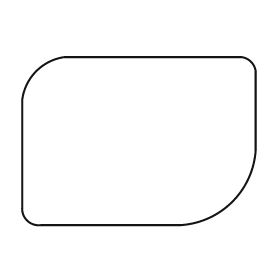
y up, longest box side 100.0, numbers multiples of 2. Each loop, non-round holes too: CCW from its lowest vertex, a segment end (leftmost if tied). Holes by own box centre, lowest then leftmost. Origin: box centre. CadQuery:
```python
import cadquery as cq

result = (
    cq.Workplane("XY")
    .moveTo(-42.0, -36.0)
    .lineTo(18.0, -36.0)
    .threePointArc((40.0, -26.0), (50.0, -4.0))
    .lineTo(50.0, 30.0)
    .threePointArc((48.0, 34.0), (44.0, 36.0))
    .lineTo(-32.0, 36.0)
    .threePointArc((-44.0, 30.0), (-50.0, 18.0))
    .lineTo(-50.0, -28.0)
    .threePointArc((-48.0, -34.0), (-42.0, -36.0))
    .close()
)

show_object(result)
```